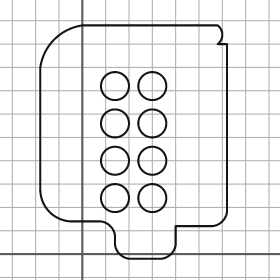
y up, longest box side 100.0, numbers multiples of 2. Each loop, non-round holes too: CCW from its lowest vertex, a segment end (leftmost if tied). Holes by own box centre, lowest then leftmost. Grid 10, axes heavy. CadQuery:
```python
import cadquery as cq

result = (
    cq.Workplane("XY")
    .moveTo(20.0, -2.0)
    .lineTo(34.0, -2.0)
    .threePointArc((38.0, 0.0), (40.0, 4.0))
    .lineTo(40.0, 12.0)
    .lineTo(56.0, 12.0)
    .threePointArc((60.0, 14.0), (62.0, 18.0))
    .lineTo(62.0, 90.0)
    .lineTo(58.0, 90.0)
    .threePointArc((60.0, 94.0), (58.0, 98.0))
    .lineTo(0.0, 98.0)
    .threePointArc((-12.0, 92.0), (-18.0, 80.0))
    .lineTo(-18.0, 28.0)
    .threePointArc((-14.0, 18.0), (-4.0, 14.0))
    .lineTo(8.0, 14.0)
    .threePointArc((12.0, 12.0), (14.0, 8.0))
    .lineTo(14.0, 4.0)
    .threePointArc((16.0, 0.0), (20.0, -2.0))
    .close()
    .moveTo(14.0, 24.0)
    .circle(6.0)
    .moveTo(30.0, 24.0)
    .circle(6.0)
    .moveTo(14.0, 40.0)
    .circle(6.0)
    .moveTo(30.0, 40.0)
    .circle(6.0)
    .moveTo(14.0, 56.0)
    .circle(6.0)
    .moveTo(30.0, 56.0)
    .circle(6.0)
    .moveTo(14.0, 72.0)
    .circle(6.0)
    .moveTo(30.0, 72.0)
    .circle(6.0)
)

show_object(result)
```